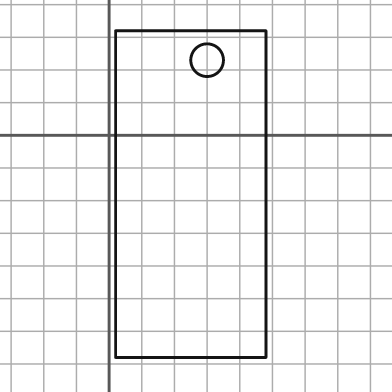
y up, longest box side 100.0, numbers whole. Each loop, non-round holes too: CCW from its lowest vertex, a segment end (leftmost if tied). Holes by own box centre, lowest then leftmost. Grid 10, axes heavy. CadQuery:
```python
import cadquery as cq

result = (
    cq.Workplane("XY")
    .moveTo(2.0, -68.0)
    .lineTo(48.0, -68.0)
    .lineTo(48.0, 32.0)
    .lineTo(2.0, 32.0)
    .close()
    .moveTo(30.0, 23.0)
    .circle(5.0)
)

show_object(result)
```